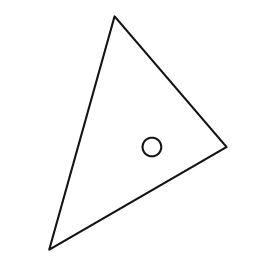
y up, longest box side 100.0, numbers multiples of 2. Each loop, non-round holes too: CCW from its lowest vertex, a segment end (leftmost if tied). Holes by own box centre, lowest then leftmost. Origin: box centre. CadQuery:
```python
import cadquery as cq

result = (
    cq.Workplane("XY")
    .moveTo(-38.0, -50.0)
    .lineTo(38.0, -6.0)
    .lineTo(-10.0, 50.0)
    .close()
    .moveTo(6.0, -6.0)
    .circle(4.0)
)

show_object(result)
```